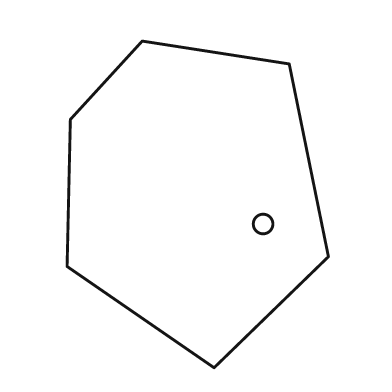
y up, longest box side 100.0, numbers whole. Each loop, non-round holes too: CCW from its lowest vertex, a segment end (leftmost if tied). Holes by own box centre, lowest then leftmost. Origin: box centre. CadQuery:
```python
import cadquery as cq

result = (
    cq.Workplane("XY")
    .moveTo(5.0, -50.0)
    .lineTo(40.0, -16.0)
    .lineTo(28.0, 43.0)
    .lineTo(-17.0, 50.0)
    .lineTo(-39.0, 26.0)
    .lineTo(-40.0, -19.0)
    .close()
    .moveTo(20.0, -6.0)
    .circle(3.0)
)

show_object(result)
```